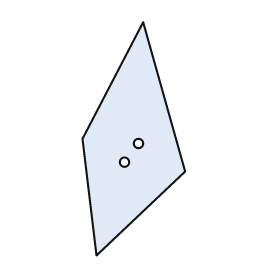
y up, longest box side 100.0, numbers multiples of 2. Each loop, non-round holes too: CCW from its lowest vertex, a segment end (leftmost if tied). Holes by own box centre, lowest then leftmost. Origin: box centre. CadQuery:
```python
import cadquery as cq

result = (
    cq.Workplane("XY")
    .moveTo(-16.0, -50.0)
    .lineTo(22.0, -14.0)
    .lineTo(4.0, 50.0)
    .lineTo(-22.0, 0.0)
    .close()
    .moveTo(-4.0, -10.0)
    .circle(2.0)
    .moveTo(2.0, -2.0)
    .circle(2.0)
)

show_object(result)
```